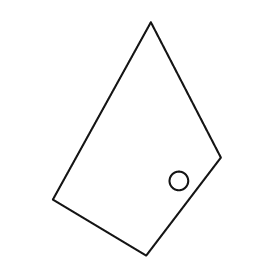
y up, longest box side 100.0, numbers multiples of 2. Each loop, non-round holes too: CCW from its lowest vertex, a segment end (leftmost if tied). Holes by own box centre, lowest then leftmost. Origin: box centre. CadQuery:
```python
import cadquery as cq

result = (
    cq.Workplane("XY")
    .moveTo(4.0, -50.0)
    .lineTo(36.0, -8.0)
    .lineTo(6.0, 50.0)
    .lineTo(-36.0, -26.0)
    .close()
    .moveTo(18.0, -18.0)
    .circle(4.0)
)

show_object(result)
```